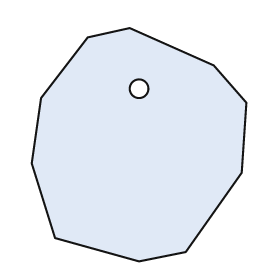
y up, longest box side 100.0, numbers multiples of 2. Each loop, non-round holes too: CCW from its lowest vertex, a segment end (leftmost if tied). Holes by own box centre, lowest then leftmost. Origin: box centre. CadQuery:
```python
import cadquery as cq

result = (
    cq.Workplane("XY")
    .moveTo(0.0, -50.0)
    .lineTo(20.0, -46.0)
    .lineTo(44.0, -12.0)
    .lineTo(46.0, 18.0)
    .lineTo(32.0, 34.0)
    .lineTo(-4.0, 50.0)
    .lineTo(-22.0, 46.0)
    .lineTo(-42.0, 20.0)
    .lineTo(-46.0, -8.0)
    .lineTo(-36.0, -40.0)
    .close()
    .moveTo(0.0, 24.0)
    .circle(4.0)
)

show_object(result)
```